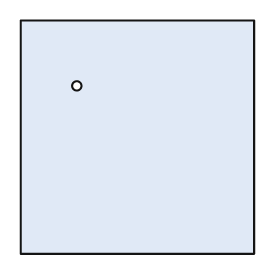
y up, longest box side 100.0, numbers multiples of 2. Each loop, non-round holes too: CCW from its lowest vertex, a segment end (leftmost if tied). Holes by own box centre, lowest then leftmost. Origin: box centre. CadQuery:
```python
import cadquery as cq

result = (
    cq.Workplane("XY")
    .moveTo(-50.0, -50.0)
    .lineTo(50.0, -50.0)
    .lineTo(50.0, 50.0)
    .lineTo(-50.0, 50.0)
    .close()
    .moveTo(-26.0, 22.0)
    .circle(2.0)
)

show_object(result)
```